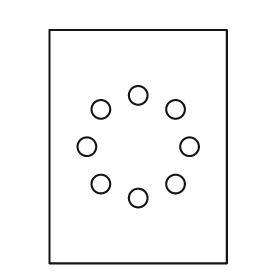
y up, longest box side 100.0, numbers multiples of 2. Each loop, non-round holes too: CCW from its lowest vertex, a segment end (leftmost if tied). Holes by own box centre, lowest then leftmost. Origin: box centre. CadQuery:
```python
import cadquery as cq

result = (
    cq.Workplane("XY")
    .moveTo(-38.0, -50.0)
    .lineTo(38.0, -50.0)
    .lineTo(38.0, 50.0)
    .lineTo(-38.0, 50.0)
    .close()
    .moveTo(0.0, -22.0)
    .circle(4.0)
    .moveTo(-16.0, -16.0)
    .circle(4.0)
    .moveTo(16.0, -16.0)
    .circle(4.0)
    .moveTo(-22.0, 0.0)
    .circle(4.0)
    .moveTo(22.0, 0.0)
    .circle(4.0)
    .moveTo(-16.0, 16.0)
    .circle(4.0)
    .moveTo(16.0, 16.0)
    .circle(4.0)
    .moveTo(0.0, 22.0)
    .circle(4.0)
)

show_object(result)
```